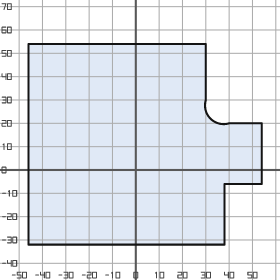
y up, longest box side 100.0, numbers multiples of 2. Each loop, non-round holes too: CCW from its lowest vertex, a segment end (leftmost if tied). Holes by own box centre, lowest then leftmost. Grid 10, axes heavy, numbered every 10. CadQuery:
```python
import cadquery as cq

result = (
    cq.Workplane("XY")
    .moveTo(-46.0, -32.0)
    .lineTo(38.0, -32.0)
    .lineTo(38.0, -6.0)
    .lineTo(54.0, -6.0)
    .lineTo(54.0, 20.0)
    .lineTo(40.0, 20.0)
    .threePointArc((32.0, 22.0), (30.0, 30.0))
    .lineTo(30.0, 54.0)
    .lineTo(-46.0, 54.0)
    .close()
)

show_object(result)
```